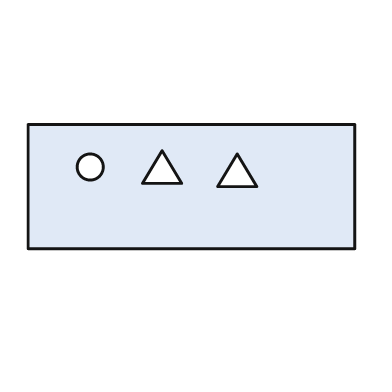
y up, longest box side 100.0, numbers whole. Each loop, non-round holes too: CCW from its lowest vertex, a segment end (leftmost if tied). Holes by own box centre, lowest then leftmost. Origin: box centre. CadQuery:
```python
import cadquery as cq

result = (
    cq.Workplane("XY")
    .moveTo(-50.0, -19.0)
    .lineTo(50.0, -19.0)
    .lineTo(50.0, 19.0)
    .lineTo(-50.0, 19.0)
    .close()
    .moveTo(8.0, 0.0)
    .lineTo(20.0, 0.0)
    .lineTo(14.0, 10.0)
    .close()
    .moveTo(-31.0, 6.0)
    .circle(4.0)
    .moveTo(-15.0, 1.0)
    .lineTo(-3.0, 1.0)
    .lineTo(-9.0, 11.0)
    .close()
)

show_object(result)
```